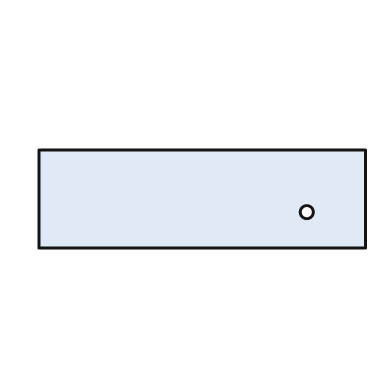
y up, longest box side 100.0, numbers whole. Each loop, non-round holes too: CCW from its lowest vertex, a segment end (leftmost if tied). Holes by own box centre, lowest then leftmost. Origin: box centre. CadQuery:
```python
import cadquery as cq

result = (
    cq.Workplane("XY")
    .moveTo(-50.0, -15.0)
    .lineTo(50.0, -15.0)
    .lineTo(50.0, 15.0)
    .lineTo(-50.0, 15.0)
    .close()
    .moveTo(32.0, -4.0)
    .circle(2.0)
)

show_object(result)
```